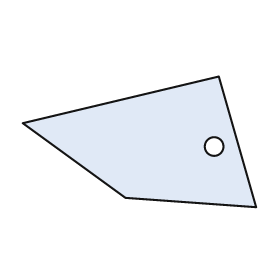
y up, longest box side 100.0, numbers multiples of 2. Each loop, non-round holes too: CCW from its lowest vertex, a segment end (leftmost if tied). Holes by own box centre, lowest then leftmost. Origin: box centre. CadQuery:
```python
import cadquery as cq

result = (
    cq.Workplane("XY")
    .moveTo(50.0, -28.0)
    .lineTo(34.0, 28.0)
    .lineTo(-50.0, 8.0)
    .lineTo(-6.0, -24.0)
    .close()
    .moveTo(32.0, -2.0)
    .circle(4.0)
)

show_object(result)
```